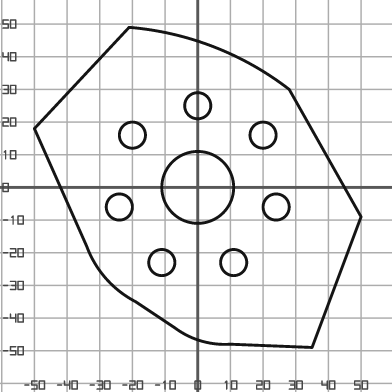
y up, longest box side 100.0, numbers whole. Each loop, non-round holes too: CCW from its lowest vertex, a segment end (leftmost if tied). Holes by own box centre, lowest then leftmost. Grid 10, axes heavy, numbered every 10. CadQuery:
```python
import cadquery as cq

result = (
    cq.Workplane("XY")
    .moveTo(35.0, -49.0)
    .lineTo(50.0, -9.0)
    .lineTo(28.0, 30.0)
    .threePointArc((5.0, 43.0), (-21.0, 49.0))
    .lineTo(-50.0, 18.0)
    .lineTo(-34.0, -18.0)
    .threePointArc((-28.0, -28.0), (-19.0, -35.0))
    .lineTo(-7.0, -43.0)
    .threePointArc((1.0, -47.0), (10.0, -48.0))
    .close()
    .moveTo(-11.0, -23.0)
    .circle(4.0)
    .moveTo(11.0, -23.0)
    .circle(4.0)
    .moveTo(-24.0, -6.0)
    .circle(4.0)
    .moveTo(24.0, -6.0)
    .circle(4.0)
    .moveTo(0.0, 0.0)
    .circle(11.0)
    .moveTo(-20.0, 16.0)
    .circle(4.0)
    .moveTo(20.0, 16.0)
    .circle(4.0)
    .moveTo(0.0, 25.0)
    .circle(4.0)
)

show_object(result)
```